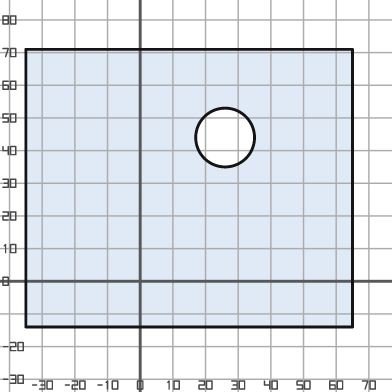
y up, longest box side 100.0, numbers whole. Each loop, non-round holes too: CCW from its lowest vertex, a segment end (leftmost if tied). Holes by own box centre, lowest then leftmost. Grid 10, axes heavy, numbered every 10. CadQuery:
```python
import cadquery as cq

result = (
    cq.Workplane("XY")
    .moveTo(-35.0, -14.0)
    .lineTo(65.0, -14.0)
    .lineTo(65.0, 71.0)
    .lineTo(-35.0, 71.0)
    .close()
    .moveTo(26.0, 44.0)
    .circle(9.0)
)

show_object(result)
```